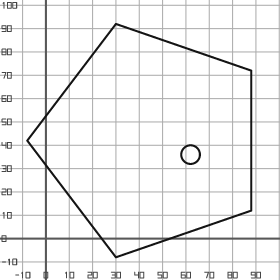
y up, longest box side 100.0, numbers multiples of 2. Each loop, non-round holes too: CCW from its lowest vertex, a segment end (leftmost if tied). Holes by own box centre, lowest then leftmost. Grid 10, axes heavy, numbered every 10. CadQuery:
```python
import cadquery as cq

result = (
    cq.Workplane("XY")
    .moveTo(30.0, -8.0)
    .lineTo(88.0, 12.0)
    .lineTo(88.0, 72.0)
    .lineTo(30.0, 92.0)
    .lineTo(-8.0, 42.0)
    .close()
    .moveTo(62.0, 36.0)
    .circle(4.0)
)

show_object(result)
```